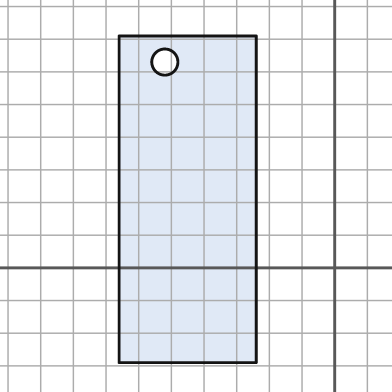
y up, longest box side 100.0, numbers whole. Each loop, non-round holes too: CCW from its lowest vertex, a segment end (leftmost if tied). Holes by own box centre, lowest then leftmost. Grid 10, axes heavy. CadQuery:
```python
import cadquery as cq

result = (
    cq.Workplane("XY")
    .moveTo(-66.0, -29.0)
    .lineTo(-24.0, -29.0)
    .lineTo(-24.0, 71.0)
    .lineTo(-66.0, 71.0)
    .close()
    .moveTo(-52.0, 63.0)
    .circle(4.0)
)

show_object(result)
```